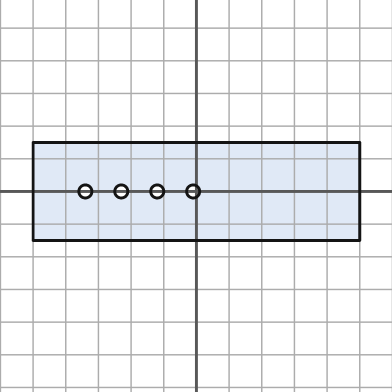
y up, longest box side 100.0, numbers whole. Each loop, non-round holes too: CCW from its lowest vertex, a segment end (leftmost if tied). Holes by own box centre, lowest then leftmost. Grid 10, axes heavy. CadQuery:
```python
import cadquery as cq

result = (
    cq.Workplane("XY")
    .moveTo(-50.0, -15.0)
    .lineTo(50.0, -15.0)
    .lineTo(50.0, 15.0)
    .lineTo(-50.0, 15.0)
    .close()
    .moveTo(-34.0, 0.0)
    .circle(2.0)
    .moveTo(-23.0, 0.0)
    .circle(2.0)
    .moveTo(-12.0, 0.0)
    .circle(2.0)
    .moveTo(-1.0, 0.0)
    .circle(2.0)
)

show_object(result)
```